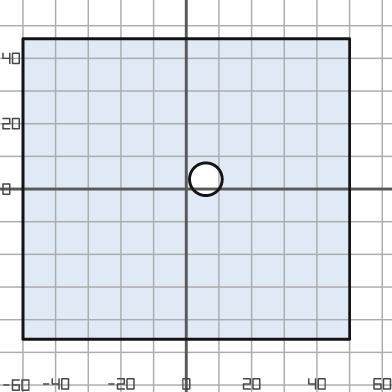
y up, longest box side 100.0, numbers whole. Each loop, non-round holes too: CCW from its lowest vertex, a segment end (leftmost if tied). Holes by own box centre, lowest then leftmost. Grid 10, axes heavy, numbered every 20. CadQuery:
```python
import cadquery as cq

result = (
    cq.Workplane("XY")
    .moveTo(-50.0, -46.0)
    .lineTo(50.0, -46.0)
    .lineTo(50.0, 46.0)
    .lineTo(-50.0, 46.0)
    .close()
    .moveTo(6.0, 3.0)
    .circle(5.0)
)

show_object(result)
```